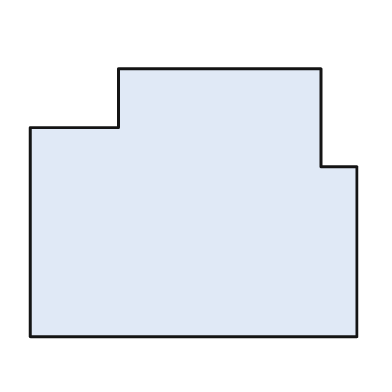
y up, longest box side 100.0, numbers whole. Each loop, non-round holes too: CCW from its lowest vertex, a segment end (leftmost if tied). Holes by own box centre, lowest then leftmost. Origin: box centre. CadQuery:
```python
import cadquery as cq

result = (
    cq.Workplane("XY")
    .moveTo(-50.0, -41.0)
    .lineTo(50.0, -41.0)
    .lineTo(50.0, 11.0)
    .lineTo(39.0, 11.0)
    .lineTo(39.0, 41.0)
    .lineTo(-23.0, 41.0)
    .lineTo(-23.0, 23.0)
    .lineTo(-50.0, 23.0)
    .close()
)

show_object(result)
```